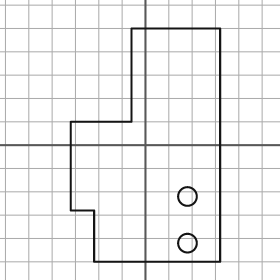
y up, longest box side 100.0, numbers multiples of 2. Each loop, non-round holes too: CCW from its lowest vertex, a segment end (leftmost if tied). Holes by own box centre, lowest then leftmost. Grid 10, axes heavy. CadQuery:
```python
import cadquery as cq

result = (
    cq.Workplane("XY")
    .moveTo(-22.0, -50.0)
    .lineTo(32.0, -50.0)
    .lineTo(32.0, 50.0)
    .lineTo(-6.0, 50.0)
    .lineTo(-6.0, 10.0)
    .lineTo(-32.0, 10.0)
    .lineTo(-32.0, -28.0)
    .lineTo(-22.0, -28.0)
    .close()
    .moveTo(18.0, -42.0)
    .circle(4.0)
    .moveTo(18.0, -22.0)
    .circle(4.0)
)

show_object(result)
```